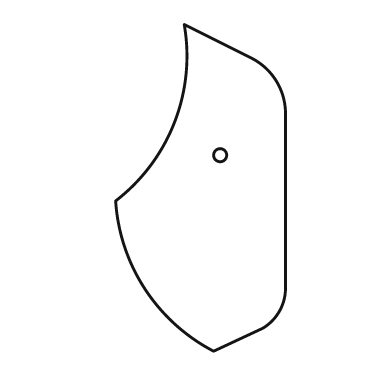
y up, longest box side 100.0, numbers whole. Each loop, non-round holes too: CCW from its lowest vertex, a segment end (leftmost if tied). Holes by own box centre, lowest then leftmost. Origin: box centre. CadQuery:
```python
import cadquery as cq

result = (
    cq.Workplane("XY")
    .moveTo(4.0, -50.0)
    .lineTo(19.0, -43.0)
    .threePointArc((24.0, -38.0), (26.0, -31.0))
    .lineTo(26.0, 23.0)
    .threePointArc((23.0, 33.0), (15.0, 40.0))
    .lineTo(-5.0, 50.0)
    .threePointArc((-8.0, 20.0), (-26.0, -4.0))
    .threePointArc((-17.0, -31.0), (4.0, -50.0))
    .close()
    .moveTo(6.0, 10.0)
    .circle(2.0)
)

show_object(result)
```